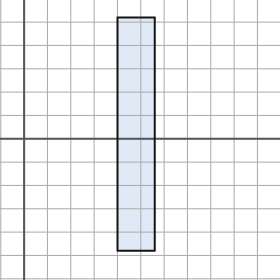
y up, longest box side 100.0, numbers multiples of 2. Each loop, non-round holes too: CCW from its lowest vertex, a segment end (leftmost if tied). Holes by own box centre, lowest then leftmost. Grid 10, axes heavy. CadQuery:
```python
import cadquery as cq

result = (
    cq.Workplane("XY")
    .moveTo(40.0, -48.0)
    .lineTo(56.0, -48.0)
    .lineTo(56.0, 52.0)
    .lineTo(40.0, 52.0)
    .close()
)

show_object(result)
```